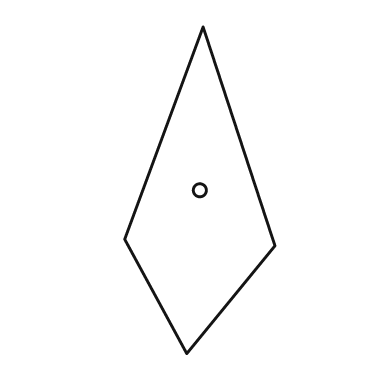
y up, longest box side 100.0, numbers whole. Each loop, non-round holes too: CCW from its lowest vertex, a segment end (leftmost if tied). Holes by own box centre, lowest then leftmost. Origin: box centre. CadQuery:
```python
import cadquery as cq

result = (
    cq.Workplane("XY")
    .moveTo(-4.0, -50.0)
    .lineTo(23.0, -17.0)
    .lineTo(1.0, 50.0)
    .lineTo(-23.0, -15.0)
    .close()
    .moveTo(0.0, 0.0)
    .circle(2.0)
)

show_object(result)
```